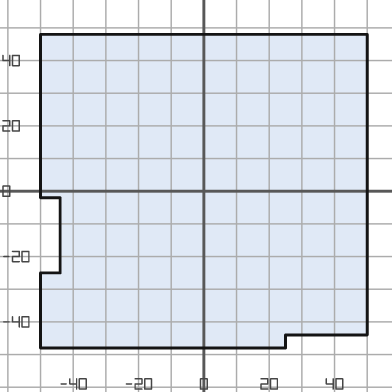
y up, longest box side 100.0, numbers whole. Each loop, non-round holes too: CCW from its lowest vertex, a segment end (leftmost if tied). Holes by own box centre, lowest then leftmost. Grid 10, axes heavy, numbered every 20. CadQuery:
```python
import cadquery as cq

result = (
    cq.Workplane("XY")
    .moveTo(-50.0, -48.0)
    .lineTo(25.0, -48.0)
    .lineTo(25.0, -44.0)
    .lineTo(50.0, -44.0)
    .lineTo(50.0, 48.0)
    .lineTo(-50.0, 48.0)
    .lineTo(-50.0, -2.0)
    .lineTo(-44.0, -2.0)
    .lineTo(-44.0, -25.0)
    .lineTo(-50.0, -25.0)
    .close()
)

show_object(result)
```